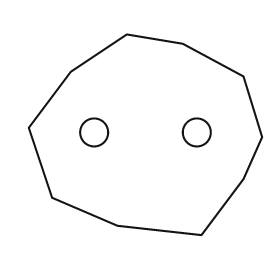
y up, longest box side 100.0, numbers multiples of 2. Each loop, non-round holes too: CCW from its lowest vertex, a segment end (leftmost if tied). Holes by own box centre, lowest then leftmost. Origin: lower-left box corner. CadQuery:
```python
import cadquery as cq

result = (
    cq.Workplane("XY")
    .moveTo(74.0, 0.0)
    .lineTo(92.0, 24.0)
    .lineTo(100.0, 42.0)
    .lineTo(92.0, 68.0)
    .lineTo(66.0, 82.0)
    .lineTo(42.0, 86.0)
    .lineTo(18.0, 70.0)
    .lineTo(0.0, 46.0)
    .lineTo(10.0, 16.0)
    .lineTo(38.0, 4.0)
    .close()
    .moveTo(28.0, 44.0)
    .circle(6.0)
    .moveTo(72.0, 44.0)
    .circle(6.0)
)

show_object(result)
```